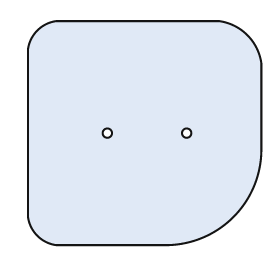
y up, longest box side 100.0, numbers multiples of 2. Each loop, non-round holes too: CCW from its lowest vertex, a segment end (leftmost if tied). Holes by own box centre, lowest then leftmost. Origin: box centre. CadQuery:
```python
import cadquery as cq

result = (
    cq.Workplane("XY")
    .moveTo(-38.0, -48.0)
    .lineTo(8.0, -48.0)
    .threePointArc((38.0, -36.0), (50.0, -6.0))
    .lineTo(50.0, 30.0)
    .threePointArc((44.0, 42.0), (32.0, 48.0))
    .lineTo(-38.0, 48.0)
    .threePointArc((-46.0, 44.0), (-50.0, 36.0))
    .lineTo(-50.0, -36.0)
    .threePointArc((-46.0, -44.0), (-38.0, -48.0))
    .close()
    .moveTo(-16.0, 0.0)
    .circle(2.0)
    .moveTo(18.0, 0.0)
    .circle(2.0)
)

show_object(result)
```